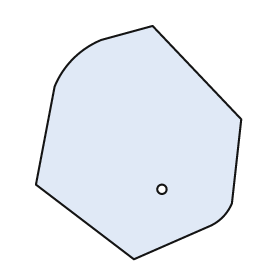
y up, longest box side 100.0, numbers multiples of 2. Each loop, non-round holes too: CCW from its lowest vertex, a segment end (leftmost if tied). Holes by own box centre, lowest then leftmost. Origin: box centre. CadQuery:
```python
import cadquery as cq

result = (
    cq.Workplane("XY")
    .moveTo(-2.0, -50.0)
    .lineTo(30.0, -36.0)
    .threePointArc((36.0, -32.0), (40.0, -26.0))
    .lineTo(44.0, 10.0)
    .lineTo(6.0, 50.0)
    .lineTo(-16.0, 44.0)
    .threePointArc((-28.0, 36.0), (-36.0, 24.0))
    .lineTo(-44.0, -18.0)
    .close()
    .moveTo(10.0, -20.0)
    .circle(2.0)
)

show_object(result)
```